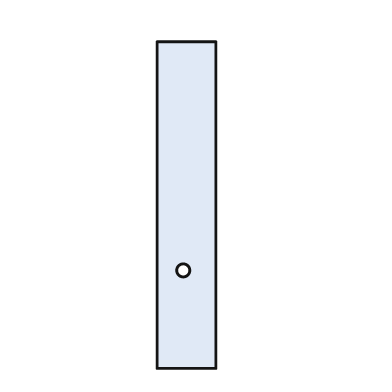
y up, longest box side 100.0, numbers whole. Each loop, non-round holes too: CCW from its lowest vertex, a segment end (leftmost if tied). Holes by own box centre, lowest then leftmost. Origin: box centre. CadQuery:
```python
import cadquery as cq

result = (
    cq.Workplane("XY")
    .moveTo(-9.0, -50.0)
    .lineTo(9.0, -50.0)
    .lineTo(9.0, 50.0)
    .lineTo(-9.0, 50.0)
    .close()
    .moveTo(-1.0, -20.0)
    .circle(2.0)
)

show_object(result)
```